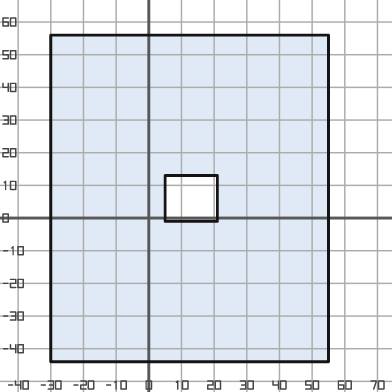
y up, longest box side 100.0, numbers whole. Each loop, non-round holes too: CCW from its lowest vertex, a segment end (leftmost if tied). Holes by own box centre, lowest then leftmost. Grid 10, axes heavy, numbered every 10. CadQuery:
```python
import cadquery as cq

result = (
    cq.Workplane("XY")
    .moveTo(-30.0, -44.0)
    .lineTo(55.0, -44.0)
    .lineTo(55.0, 56.0)
    .lineTo(-30.0, 56.0)
    .close()
    .moveTo(5.0, -1.0)
    .lineTo(21.0, -1.0)
    .lineTo(21.0, 13.0)
    .lineTo(5.0, 13.0)
    .close()
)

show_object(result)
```